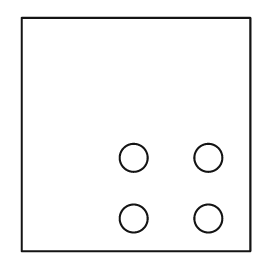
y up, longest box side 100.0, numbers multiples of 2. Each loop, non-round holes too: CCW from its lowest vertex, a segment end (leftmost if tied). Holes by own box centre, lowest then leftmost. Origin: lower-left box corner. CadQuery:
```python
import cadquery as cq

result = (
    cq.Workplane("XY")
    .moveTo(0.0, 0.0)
    .lineTo(98.0, 0.0)
    .lineTo(98.0, 100.0)
    .lineTo(0.0, 100.0)
    .close()
    .moveTo(48.0, 14.0)
    .circle(6.0)
    .moveTo(80.0, 14.0)
    .circle(6.0)
    .moveTo(48.0, 40.0)
    .circle(6.0)
    .moveTo(80.0, 40.0)
    .circle(6.0)
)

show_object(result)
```